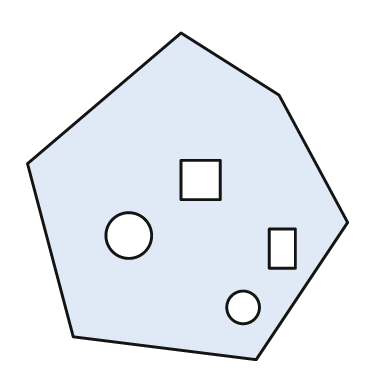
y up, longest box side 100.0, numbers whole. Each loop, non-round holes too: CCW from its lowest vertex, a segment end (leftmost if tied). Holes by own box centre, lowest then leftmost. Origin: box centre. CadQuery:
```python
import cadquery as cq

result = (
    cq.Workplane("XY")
    .moveTo(21.0, -50.0)
    .lineTo(49.0, -8.0)
    .lineTo(28.0, 31.0)
    .lineTo(-2.0, 50.0)
    .lineTo(-49.0, 10.0)
    .lineTo(-35.0, -43.0)
    .close()
    .moveTo(17.0, -34.0)
    .circle(5.0)
    .moveTo(25.0, -22.0)
    .lineTo(33.0, -22.0)
    .lineTo(33.0, -10.0)
    .lineTo(25.0, -10.0)
    .close()
    .moveTo(-18.0, -12.0)
    .circle(7.0)
    .moveTo(-2.0, -1.0)
    .lineTo(10.0, -1.0)
    .lineTo(10.0, 11.0)
    .lineTo(-2.0, 11.0)
    .close()
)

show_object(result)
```